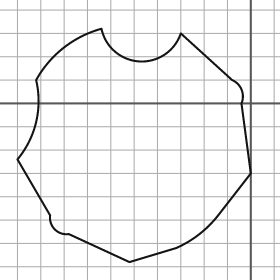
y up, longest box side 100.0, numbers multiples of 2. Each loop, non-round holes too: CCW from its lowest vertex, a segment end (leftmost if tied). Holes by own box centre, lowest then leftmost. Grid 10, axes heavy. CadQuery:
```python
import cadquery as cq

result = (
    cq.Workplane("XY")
    .moveTo(-52.0, -68.0)
    .lineTo(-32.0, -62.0)
    .threePointArc((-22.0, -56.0), (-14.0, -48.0))
    .lineTo(0.0, -30.0)
    .lineTo(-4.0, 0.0)
    .threePointArc((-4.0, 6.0), (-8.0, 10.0))
    .lineTo(-30.0, 30.0)
    .threePointArc((-48.0, 18.0), (-64.0, 32.0))
    .threePointArc((-80.0, 24.0), (-92.0, 10.0))
    .threePointArc((-92.0, -8.0), (-100.0, -24.0))
    .lineTo(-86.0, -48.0)
    .threePointArc((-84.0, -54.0), (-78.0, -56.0))
    .close()
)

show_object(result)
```